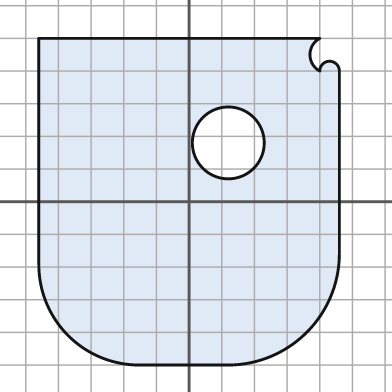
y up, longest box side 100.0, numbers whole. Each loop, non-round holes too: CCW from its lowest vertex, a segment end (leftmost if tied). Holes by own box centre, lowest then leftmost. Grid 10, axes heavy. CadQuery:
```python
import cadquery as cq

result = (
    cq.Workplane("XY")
    .moveTo(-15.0, -50.0)
    .lineTo(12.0, -50.0)
    .threePointArc((36.0, -40.0), (46.0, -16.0))
    .lineTo(46.0, 40.0)
    .threePointArc((43.0, 43.0), (40.0, 40.0))
    .threePointArc((37.0, 45.0), (40.0, 50.0))
    .lineTo(-46.0, 50.0)
    .lineTo(-46.0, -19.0)
    .threePointArc((-37.0, -41.0), (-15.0, -50.0))
    .close()
    .moveTo(12.0, 18.0)
    .circle(11.0)
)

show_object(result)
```